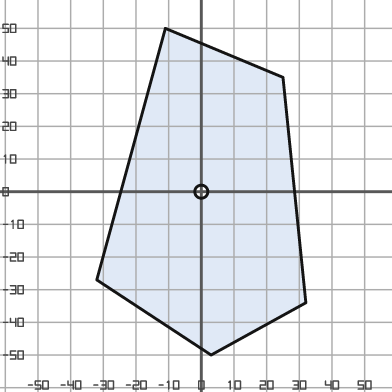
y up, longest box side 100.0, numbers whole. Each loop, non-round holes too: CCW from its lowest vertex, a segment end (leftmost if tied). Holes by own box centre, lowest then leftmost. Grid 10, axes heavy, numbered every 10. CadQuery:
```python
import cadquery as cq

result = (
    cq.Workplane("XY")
    .moveTo(3.0, -50.0)
    .lineTo(32.0, -34.0)
    .lineTo(25.0, 35.0)
    .lineTo(-11.0, 50.0)
    .lineTo(-32.0, -27.0)
    .close()
    .moveTo(0.0, 0.0)
    .circle(2.0)
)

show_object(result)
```